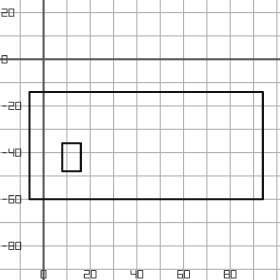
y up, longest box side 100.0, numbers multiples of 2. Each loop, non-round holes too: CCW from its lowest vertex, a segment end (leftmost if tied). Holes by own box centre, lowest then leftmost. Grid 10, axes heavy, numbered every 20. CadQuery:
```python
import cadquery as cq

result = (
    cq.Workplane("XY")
    .moveTo(-6.0, -60.0)
    .lineTo(94.0, -60.0)
    .lineTo(94.0, -14.0)
    .lineTo(-6.0, -14.0)
    .close()
    .moveTo(8.0, -48.0)
    .lineTo(16.0, -48.0)
    .lineTo(16.0, -36.0)
    .lineTo(8.0, -36.0)
    .close()
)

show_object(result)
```